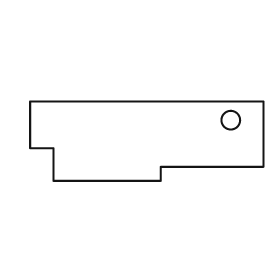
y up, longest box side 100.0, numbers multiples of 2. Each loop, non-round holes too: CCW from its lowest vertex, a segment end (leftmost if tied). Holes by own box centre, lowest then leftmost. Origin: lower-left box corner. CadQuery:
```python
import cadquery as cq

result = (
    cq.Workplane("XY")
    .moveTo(10.0, 0.0)
    .lineTo(56.0, 0.0)
    .lineTo(56.0, 6.0)
    .lineTo(100.0, 6.0)
    .lineTo(100.0, 34.0)
    .lineTo(0.0, 34.0)
    .lineTo(0.0, 14.0)
    .lineTo(10.0, 14.0)
    .close()
    .moveTo(86.0, 26.0)
    .circle(4.0)
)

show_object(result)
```